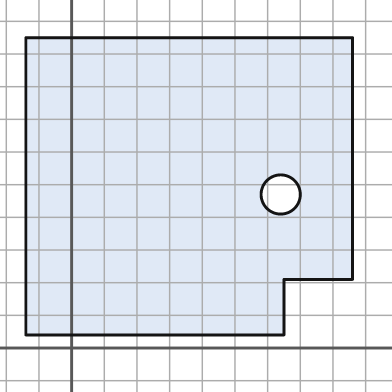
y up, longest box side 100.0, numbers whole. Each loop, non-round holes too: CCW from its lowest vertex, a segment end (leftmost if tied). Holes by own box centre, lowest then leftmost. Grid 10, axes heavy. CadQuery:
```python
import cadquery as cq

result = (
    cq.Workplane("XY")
    .moveTo(-14.0, 4.0)
    .lineTo(65.0, 4.0)
    .lineTo(65.0, 21.0)
    .lineTo(86.0, 21.0)
    .lineTo(86.0, 95.0)
    .lineTo(-14.0, 95.0)
    .close()
    .moveTo(64.0, 47.0)
    .circle(6.0)
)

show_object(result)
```